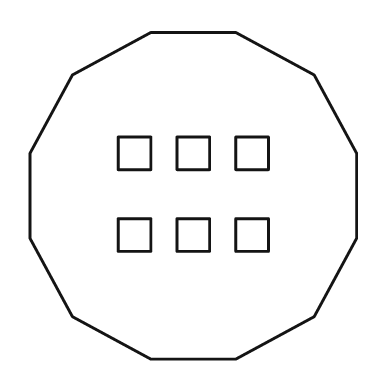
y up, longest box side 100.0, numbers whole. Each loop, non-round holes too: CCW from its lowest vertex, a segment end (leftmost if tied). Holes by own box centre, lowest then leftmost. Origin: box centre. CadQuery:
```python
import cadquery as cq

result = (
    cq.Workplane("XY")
    .moveTo(-13.0, -50.0)
    .lineTo(13.0, -50.0)
    .lineTo(37.0, -37.0)
    .lineTo(50.0, -13.0)
    .lineTo(50.0, 13.0)
    .lineTo(37.0, 37.0)
    .lineTo(13.0, 50.0)
    .lineTo(-13.0, 50.0)
    .lineTo(-37.0, 37.0)
    .lineTo(-50.0, 13.0)
    .lineTo(-50.0, -13.0)
    .lineTo(-37.0, -37.0)
    .close()
    .moveTo(-23.0, -17.0)
    .lineTo(-13.0, -17.0)
    .lineTo(-13.0, -7.0)
    .lineTo(-23.0, -7.0)
    .close()
    .moveTo(-5.0, -17.0)
    .lineTo(5.0, -17.0)
    .lineTo(5.0, -7.0)
    .lineTo(-5.0, -7.0)
    .close()
    .moveTo(13.0, -17.0)
    .lineTo(23.0, -17.0)
    .lineTo(23.0, -7.0)
    .lineTo(13.0, -7.0)
    .close()
    .moveTo(-23.0, 8.0)
    .lineTo(-13.0, 8.0)
    .lineTo(-13.0, 18.0)
    .lineTo(-23.0, 18.0)
    .close()
    .moveTo(-5.0, 8.0)
    .lineTo(5.0, 8.0)
    .lineTo(5.0, 18.0)
    .lineTo(-5.0, 18.0)
    .close()
    .moveTo(13.0, 8.0)
    .lineTo(23.0, 8.0)
    .lineTo(23.0, 18.0)
    .lineTo(13.0, 18.0)
    .close()
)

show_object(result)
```